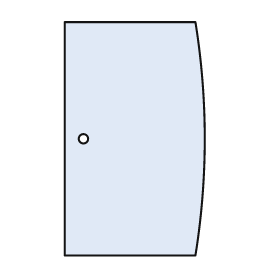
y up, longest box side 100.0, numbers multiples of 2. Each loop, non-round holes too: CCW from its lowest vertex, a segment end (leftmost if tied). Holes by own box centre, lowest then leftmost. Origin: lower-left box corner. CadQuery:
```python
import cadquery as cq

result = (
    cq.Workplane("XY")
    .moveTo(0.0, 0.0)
    .lineTo(56.0, 0.0)
    .threePointArc((60.0, 50.0), (56.0, 100.0))
    .lineTo(0.0, 100.0)
    .close()
    .moveTo(8.0, 50.0)
    .circle(2.0)
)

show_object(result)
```